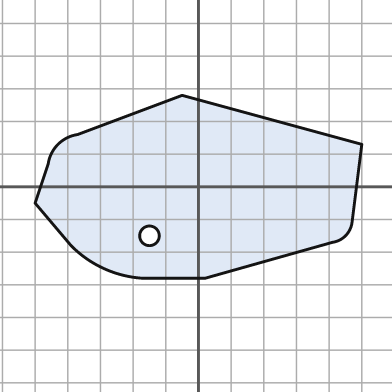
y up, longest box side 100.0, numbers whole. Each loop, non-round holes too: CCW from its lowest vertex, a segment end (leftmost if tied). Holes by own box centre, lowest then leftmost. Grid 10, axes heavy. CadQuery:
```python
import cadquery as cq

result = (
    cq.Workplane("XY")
    .moveTo(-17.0, -28.0)
    .lineTo(2.0, -28.0)
    .lineTo(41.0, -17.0)
    .threePointArc((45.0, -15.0), (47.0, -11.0))
    .lineTo(50.0, 13.0)
    .lineTo(-5.0, 28.0)
    .lineTo(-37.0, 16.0)
    .threePointArc((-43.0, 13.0), (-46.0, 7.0))
    .lineTo(-50.0, -5.0)
    .lineTo(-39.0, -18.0)
    .threePointArc((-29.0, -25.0), (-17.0, -28.0))
    .close()
    .moveTo(-15.0, -15.0)
    .circle(3.0)
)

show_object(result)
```